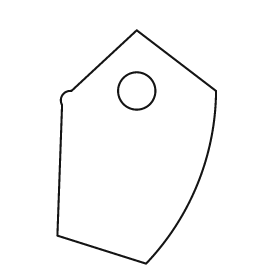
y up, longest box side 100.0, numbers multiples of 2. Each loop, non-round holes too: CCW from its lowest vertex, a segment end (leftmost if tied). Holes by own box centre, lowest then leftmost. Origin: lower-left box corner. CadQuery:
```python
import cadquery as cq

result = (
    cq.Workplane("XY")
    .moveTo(38.0, 0.0)
    .threePointArc((60.0, 34.0), (68.0, 74.0))
    .lineTo(34.0, 100.0)
    .lineTo(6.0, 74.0)
    .threePointArc((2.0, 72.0), (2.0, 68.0))
    .lineTo(0.0, 12.0)
    .close()
    .moveTo(34.0, 74.0)
    .circle(8.0)
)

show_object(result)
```